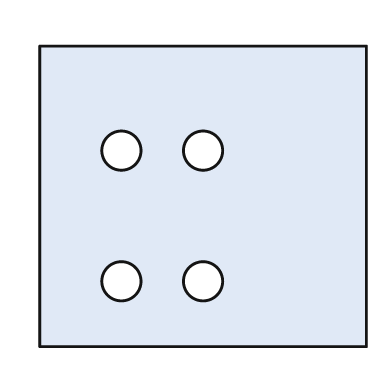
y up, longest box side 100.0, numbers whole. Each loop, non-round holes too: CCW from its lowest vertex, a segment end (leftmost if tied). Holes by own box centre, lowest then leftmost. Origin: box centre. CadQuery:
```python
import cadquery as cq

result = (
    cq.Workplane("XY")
    .moveTo(-50.0, -46.0)
    .lineTo(50.0, -46.0)
    .lineTo(50.0, 46.0)
    .lineTo(-50.0, 46.0)
    .close()
    .moveTo(-25.0, -26.0)
    .circle(6.0)
    .moveTo(0.0, -26.0)
    .circle(6.0)
    .moveTo(-25.0, 14.0)
    .circle(6.0)
    .moveTo(0.0, 14.0)
    .circle(6.0)
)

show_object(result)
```